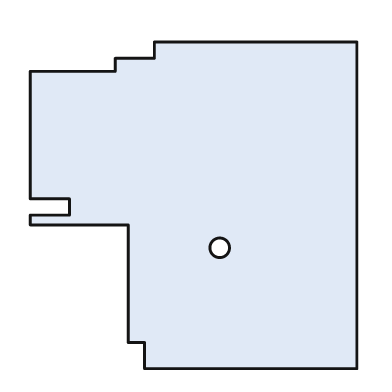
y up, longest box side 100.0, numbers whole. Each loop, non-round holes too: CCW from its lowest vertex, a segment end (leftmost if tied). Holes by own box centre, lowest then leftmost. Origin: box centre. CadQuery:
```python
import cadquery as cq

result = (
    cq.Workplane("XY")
    .moveTo(-15.0, -50.0)
    .lineTo(50.0, -50.0)
    .lineTo(50.0, 50.0)
    .lineTo(-12.0, 50.0)
    .lineTo(-12.0, 45.0)
    .lineTo(-24.0, 45.0)
    .lineTo(-24.0, 41.0)
    .lineTo(-50.0, 41.0)
    .lineTo(-50.0, 2.0)
    .lineTo(-38.0, 2.0)
    .lineTo(-38.0, -3.0)
    .lineTo(-50.0, -3.0)
    .lineTo(-50.0, -6.0)
    .lineTo(-20.0, -6.0)
    .lineTo(-20.0, -42.0)
    .lineTo(-15.0, -42.0)
    .close()
    .moveTo(8.0, -13.0)
    .circle(3.0)
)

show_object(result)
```